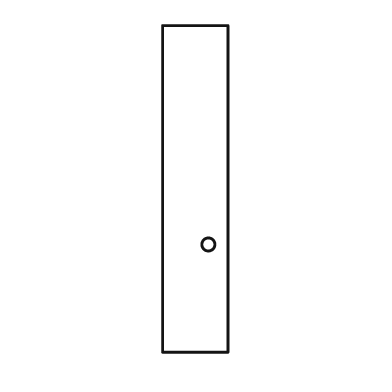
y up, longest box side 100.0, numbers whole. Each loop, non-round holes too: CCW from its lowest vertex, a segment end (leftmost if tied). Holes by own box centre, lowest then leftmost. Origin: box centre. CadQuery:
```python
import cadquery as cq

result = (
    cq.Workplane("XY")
    .moveTo(-10.0, -50.0)
    .lineTo(10.0, -50.0)
    .lineTo(10.0, 50.0)
    .lineTo(-10.0, 50.0)
    .close()
    .moveTo(4.0, -17.0)
    .circle(2.0)
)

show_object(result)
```